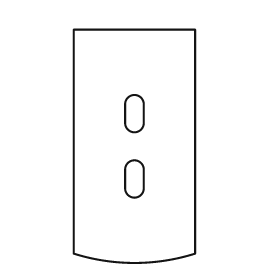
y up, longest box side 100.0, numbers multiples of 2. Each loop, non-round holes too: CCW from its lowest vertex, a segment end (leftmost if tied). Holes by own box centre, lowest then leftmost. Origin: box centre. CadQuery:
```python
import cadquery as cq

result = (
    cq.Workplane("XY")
    .moveTo(-26.0, -46.0)
    .threePointArc((0.0, -50.0), (26.0, -46.0))
    .lineTo(26.0, 50.0)
    .lineTo(-26.0, 50.0)
    .close()
    .moveTo(-4.0, -18.0)
    .threePointArc((0.0, -22.0), (4.0, -18.0))
    .lineTo(4.0, -10.0)
    .threePointArc((0.0, -6.0), (-4.0, -10.0))
    .close()
    .moveTo(-4.0, 10.0)
    .threePointArc((0.0, 6.0), (4.0, 10.0))
    .lineTo(4.0, 18.0)
    .threePointArc((0.0, 22.0), (-4.0, 18.0))
    .close()
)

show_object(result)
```